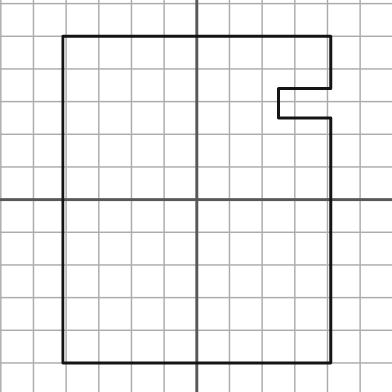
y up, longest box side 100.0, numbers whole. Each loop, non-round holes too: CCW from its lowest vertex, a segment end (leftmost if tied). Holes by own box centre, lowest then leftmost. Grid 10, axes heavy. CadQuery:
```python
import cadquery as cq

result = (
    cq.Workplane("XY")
    .moveTo(-41.0, -50.0)
    .lineTo(41.0, -50.0)
    .lineTo(41.0, 25.0)
    .lineTo(25.0, 25.0)
    .lineTo(25.0, 34.0)
    .lineTo(41.0, 34.0)
    .lineTo(41.0, 50.0)
    .lineTo(-41.0, 50.0)
    .close()
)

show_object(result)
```